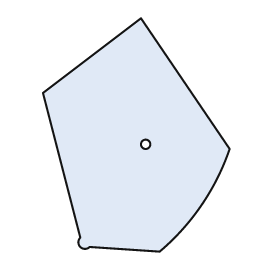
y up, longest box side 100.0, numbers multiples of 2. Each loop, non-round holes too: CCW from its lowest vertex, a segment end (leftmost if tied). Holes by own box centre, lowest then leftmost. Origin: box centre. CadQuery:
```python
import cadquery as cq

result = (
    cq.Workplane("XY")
    .moveTo(10.0, -50.0)
    .threePointArc((28.0, -30.0), (40.0, -6.0))
    .lineTo(2.0, 50.0)
    .lineTo(-40.0, 18.0)
    .lineTo(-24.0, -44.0)
    .threePointArc((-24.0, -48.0), (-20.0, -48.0))
    .close()
    .moveTo(4.0, -4.0)
    .circle(2.0)
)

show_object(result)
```